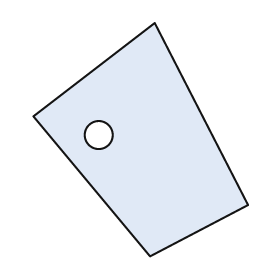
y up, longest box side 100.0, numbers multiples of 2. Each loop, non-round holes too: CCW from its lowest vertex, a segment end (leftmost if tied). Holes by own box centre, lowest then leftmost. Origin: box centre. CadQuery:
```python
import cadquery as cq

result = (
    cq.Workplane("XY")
    .moveTo(4.0, -50.0)
    .lineTo(46.0, -28.0)
    .lineTo(6.0, 50.0)
    .lineTo(-46.0, 10.0)
    .close()
    .moveTo(-18.0, 2.0)
    .circle(6.0)
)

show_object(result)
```